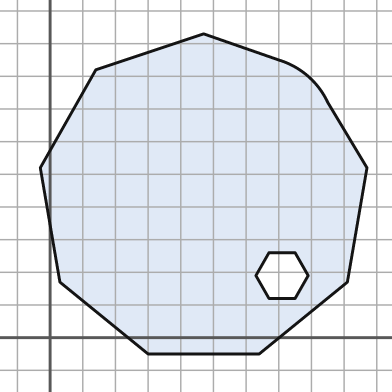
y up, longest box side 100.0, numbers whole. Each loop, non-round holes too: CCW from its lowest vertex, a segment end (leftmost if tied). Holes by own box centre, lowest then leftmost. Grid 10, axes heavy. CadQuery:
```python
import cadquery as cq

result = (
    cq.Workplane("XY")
    .moveTo(30.0, -5.0)
    .lineTo(64.0, -5.0)
    .lineTo(91.0, 17.0)
    .lineTo(97.0, 52.0)
    .lineTo(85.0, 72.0)
    .threePointArc((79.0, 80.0), (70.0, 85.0))
    .lineTo(47.0, 93.0)
    .lineTo(14.0, 82.0)
    .lineTo(-3.0, 52.0)
    .lineTo(3.0, 17.0)
    .close()
    .moveTo(67.0, 12.0)
    .lineTo(75.0, 12.0)
    .lineTo(79.0, 19.0)
    .lineTo(75.0, 26.0)
    .lineTo(67.0, 26.0)
    .lineTo(63.0, 19.0)
    .close()
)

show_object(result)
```